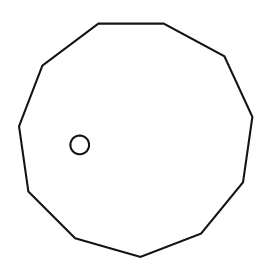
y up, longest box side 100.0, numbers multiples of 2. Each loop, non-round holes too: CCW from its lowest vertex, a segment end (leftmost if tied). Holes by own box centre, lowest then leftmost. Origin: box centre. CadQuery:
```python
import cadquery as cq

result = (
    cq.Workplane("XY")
    .moveTo(2.0, -50.0)
    .lineTo(28.0, -40.0)
    .lineTo(46.0, -18.0)
    .lineTo(50.0, 10.0)
    .lineTo(38.0, 36.0)
    .lineTo(12.0, 50.0)
    .lineTo(-16.0, 50.0)
    .lineTo(-40.0, 32.0)
    .lineTo(-50.0, 6.0)
    .lineTo(-46.0, -22.0)
    .lineTo(-26.0, -42.0)
    .close()
    .moveTo(-24.0, -2.0)
    .circle(4.0)
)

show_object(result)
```